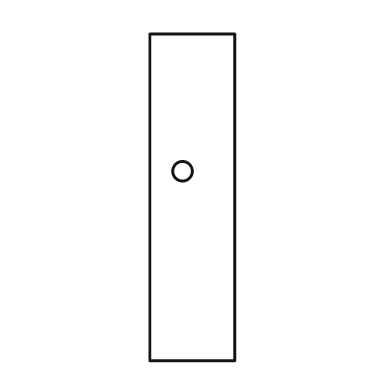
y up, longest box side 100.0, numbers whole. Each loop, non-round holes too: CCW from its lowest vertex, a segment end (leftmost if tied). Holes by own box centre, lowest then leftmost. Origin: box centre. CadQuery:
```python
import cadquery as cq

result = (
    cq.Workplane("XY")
    .moveTo(-13.0, -50.0)
    .lineTo(13.0, -50.0)
    .lineTo(13.0, 50.0)
    .lineTo(-13.0, 50.0)
    .close()
    .moveTo(-3.0, 8.0)
    .circle(3.0)
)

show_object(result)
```